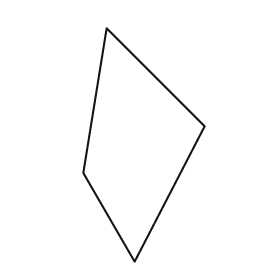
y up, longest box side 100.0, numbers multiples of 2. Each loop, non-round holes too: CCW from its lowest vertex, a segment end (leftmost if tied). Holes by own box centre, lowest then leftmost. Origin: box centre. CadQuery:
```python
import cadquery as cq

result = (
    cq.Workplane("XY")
    .moveTo(-4.0, -50.0)
    .lineTo(26.0, 8.0)
    .lineTo(-16.0, 50.0)
    .lineTo(-26.0, -12.0)
    .close()
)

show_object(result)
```